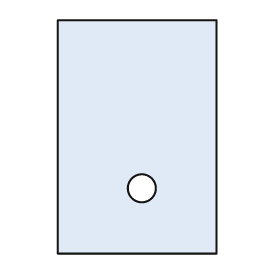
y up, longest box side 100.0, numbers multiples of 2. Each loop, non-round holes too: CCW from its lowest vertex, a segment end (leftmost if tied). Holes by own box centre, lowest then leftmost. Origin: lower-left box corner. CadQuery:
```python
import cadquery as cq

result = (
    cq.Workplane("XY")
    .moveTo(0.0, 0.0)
    .lineTo(68.0, 0.0)
    .lineTo(68.0, 100.0)
    .lineTo(0.0, 100.0)
    .close()
    .moveTo(36.0, 28.0)
    .circle(6.0)
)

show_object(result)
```